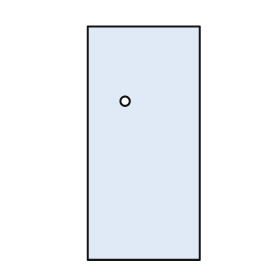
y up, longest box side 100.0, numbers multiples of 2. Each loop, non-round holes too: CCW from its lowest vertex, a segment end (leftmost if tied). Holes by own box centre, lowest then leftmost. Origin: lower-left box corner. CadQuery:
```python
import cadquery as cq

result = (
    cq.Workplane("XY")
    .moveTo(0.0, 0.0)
    .lineTo(48.0, 0.0)
    .lineTo(48.0, 100.0)
    .lineTo(0.0, 100.0)
    .close()
    .moveTo(16.0, 68.0)
    .circle(2.0)
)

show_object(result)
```